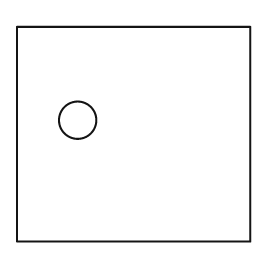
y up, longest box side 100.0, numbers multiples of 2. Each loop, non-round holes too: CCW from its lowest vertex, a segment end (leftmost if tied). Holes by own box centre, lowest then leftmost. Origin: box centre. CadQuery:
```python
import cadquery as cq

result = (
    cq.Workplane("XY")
    .moveTo(-50.0, -46.0)
    .lineTo(50.0, -46.0)
    .lineTo(50.0, 46.0)
    .lineTo(-50.0, 46.0)
    .close()
    .moveTo(-24.0, 6.0)
    .circle(8.0)
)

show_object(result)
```